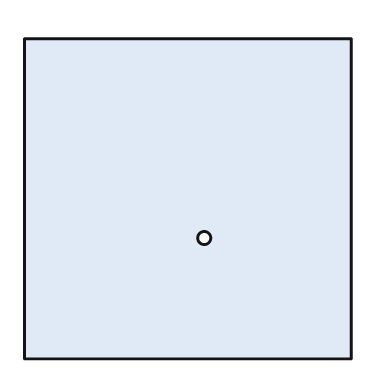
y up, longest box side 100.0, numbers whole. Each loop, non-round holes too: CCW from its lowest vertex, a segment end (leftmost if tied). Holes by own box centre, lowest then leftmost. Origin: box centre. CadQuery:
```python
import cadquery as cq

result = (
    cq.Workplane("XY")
    .moveTo(-50.0, -49.0)
    .lineTo(50.0, -49.0)
    .lineTo(50.0, 49.0)
    .lineTo(-50.0, 49.0)
    .close()
    .moveTo(5.0, -12.0)
    .circle(2.0)
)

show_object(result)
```